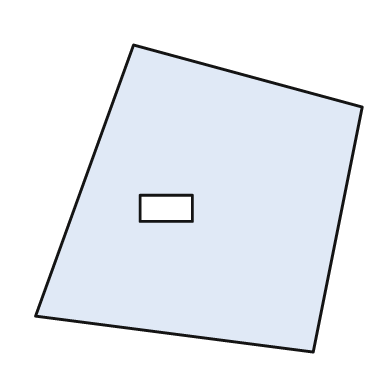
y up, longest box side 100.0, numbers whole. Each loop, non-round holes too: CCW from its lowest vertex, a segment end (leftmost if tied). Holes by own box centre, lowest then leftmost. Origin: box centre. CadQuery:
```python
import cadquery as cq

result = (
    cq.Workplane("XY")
    .moveTo(35.0, -47.0)
    .lineTo(50.0, 28.0)
    .lineTo(-20.0, 47.0)
    .lineTo(-50.0, -36.0)
    .close()
    .moveTo(-18.0, -7.0)
    .lineTo(-2.0, -7.0)
    .lineTo(-2.0, 1.0)
    .lineTo(-18.0, 1.0)
    .close()
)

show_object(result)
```